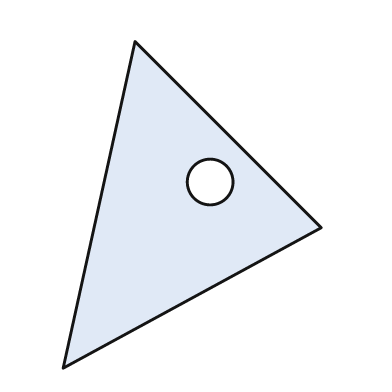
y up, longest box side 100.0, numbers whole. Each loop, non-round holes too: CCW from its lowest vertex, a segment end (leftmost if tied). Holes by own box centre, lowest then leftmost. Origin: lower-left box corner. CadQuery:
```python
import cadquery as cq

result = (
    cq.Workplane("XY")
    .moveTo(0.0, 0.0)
    .lineTo(79.0, 43.0)
    .lineTo(22.0, 100.0)
    .close()
    .moveTo(45.0, 57.0)
    .circle(7.0)
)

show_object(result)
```